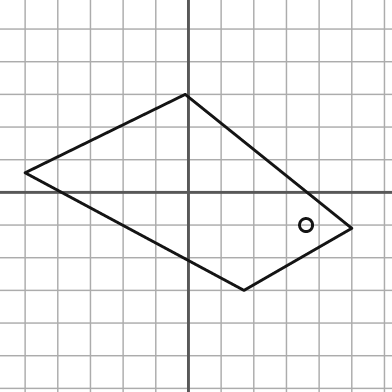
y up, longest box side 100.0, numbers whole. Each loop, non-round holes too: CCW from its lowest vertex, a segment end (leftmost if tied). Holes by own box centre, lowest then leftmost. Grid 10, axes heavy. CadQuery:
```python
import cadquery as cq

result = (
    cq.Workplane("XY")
    .moveTo(17.0, -30.0)
    .lineTo(50.0, -11.0)
    .lineTo(-1.0, 30.0)
    .lineTo(-50.0, 6.0)
    .close()
    .moveTo(36.0, -10.0)
    .circle(2.0)
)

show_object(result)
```